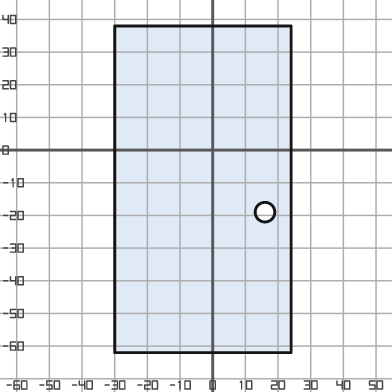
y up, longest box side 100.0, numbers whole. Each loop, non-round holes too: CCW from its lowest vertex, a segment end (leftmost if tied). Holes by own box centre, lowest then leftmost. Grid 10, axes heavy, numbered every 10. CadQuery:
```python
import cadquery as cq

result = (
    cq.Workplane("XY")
    .moveTo(-30.0, -62.0)
    .lineTo(24.0, -62.0)
    .lineTo(24.0, 38.0)
    .lineTo(-30.0, 38.0)
    .close()
    .moveTo(16.0, -19.0)
    .circle(3.0)
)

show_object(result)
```